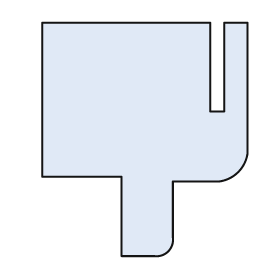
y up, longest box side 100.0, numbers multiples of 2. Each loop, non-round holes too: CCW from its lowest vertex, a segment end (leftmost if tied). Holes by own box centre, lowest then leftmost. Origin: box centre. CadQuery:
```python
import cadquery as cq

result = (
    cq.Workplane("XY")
    .moveTo(-10.0, -50.0)
    .lineTo(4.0, -50.0)
    .threePointArc((10.0, -48.0), (12.0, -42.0))
    .lineTo(12.0, -18.0)
    .lineTo(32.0, -18.0)
    .threePointArc((40.0, -14.0), (44.0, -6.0))
    .lineTo(44.0, 50.0)
    .lineTo(34.0, 50.0)
    .lineTo(34.0, 12.0)
    .lineTo(28.0, 12.0)
    .lineTo(28.0, 50.0)
    .lineTo(-44.0, 50.0)
    .lineTo(-44.0, -16.0)
    .lineTo(-10.0, -16.0)
    .close()
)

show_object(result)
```